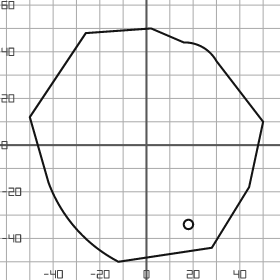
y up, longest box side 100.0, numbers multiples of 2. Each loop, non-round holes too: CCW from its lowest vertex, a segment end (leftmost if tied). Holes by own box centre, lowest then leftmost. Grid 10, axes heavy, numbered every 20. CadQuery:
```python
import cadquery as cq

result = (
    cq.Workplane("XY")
    .moveTo(-12.0, -50.0)
    .lineTo(28.0, -44.0)
    .lineTo(44.0, -18.0)
    .lineTo(50.0, 10.0)
    .lineTo(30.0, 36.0)
    .threePointArc((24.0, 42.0), (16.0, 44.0))
    .lineTo(2.0, 50.0)
    .lineTo(-26.0, 48.0)
    .lineTo(-50.0, 12.0)
    .lineTo(-42.0, -16.0)
    .threePointArc((-30.0, -36.0), (-12.0, -50.0))
    .close()
    .moveTo(18.0, -34.0)
    .circle(2.0)
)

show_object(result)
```